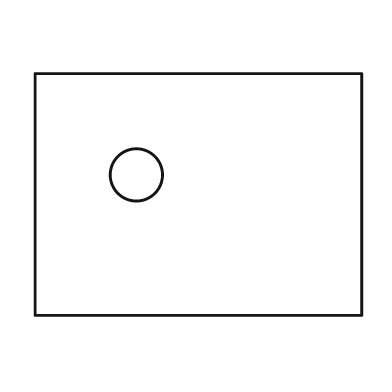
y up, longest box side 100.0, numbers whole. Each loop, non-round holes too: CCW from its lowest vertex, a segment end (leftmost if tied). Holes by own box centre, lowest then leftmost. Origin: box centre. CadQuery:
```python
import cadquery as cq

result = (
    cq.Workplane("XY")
    .moveTo(-50.0, -37.0)
    .lineTo(50.0, -37.0)
    .lineTo(50.0, 37.0)
    .lineTo(-50.0, 37.0)
    .close()
    .moveTo(-19.0, 6.0)
    .circle(8.0)
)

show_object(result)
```